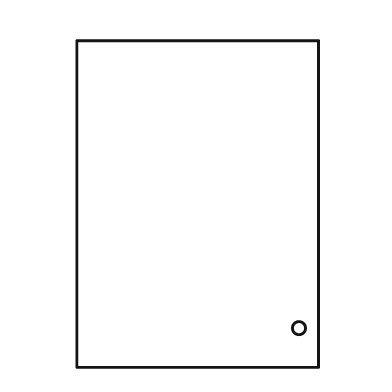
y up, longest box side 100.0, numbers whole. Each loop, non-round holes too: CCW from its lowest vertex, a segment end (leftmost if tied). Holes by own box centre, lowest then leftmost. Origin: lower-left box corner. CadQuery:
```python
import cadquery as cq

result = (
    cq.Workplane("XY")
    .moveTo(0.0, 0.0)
    .lineTo(74.0, 0.0)
    .lineTo(74.0, 100.0)
    .lineTo(0.0, 100.0)
    .close()
    .moveTo(68.0, 12.0)
    .circle(2.0)
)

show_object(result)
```